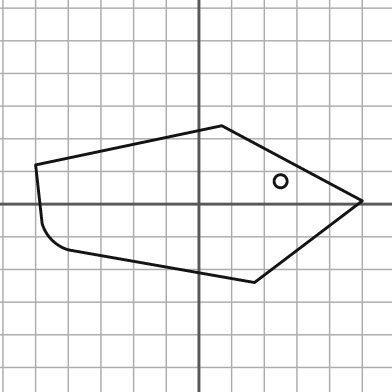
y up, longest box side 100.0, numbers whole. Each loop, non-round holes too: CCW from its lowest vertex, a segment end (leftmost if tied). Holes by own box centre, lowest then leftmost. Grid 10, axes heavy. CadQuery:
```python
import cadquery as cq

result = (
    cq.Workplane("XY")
    .moveTo(17.0, -24.0)
    .lineTo(50.0, 1.0)
    .lineTo(7.0, 24.0)
    .lineTo(-50.0, 12.0)
    .lineTo(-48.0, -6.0)
    .threePointArc((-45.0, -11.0), (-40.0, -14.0))
    .close()
    .moveTo(25.0, 7.0)
    .circle(2.0)
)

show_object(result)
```